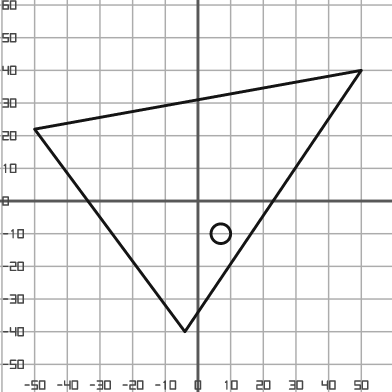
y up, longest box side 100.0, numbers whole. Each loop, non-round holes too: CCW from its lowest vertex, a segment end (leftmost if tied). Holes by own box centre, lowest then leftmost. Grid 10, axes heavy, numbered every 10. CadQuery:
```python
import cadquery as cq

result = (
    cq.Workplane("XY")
    .moveTo(-4.0, -40.0)
    .lineTo(50.0, 40.0)
    .lineTo(-50.0, 22.0)
    .close()
    .moveTo(7.0, -10.0)
    .circle(3.0)
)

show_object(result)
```